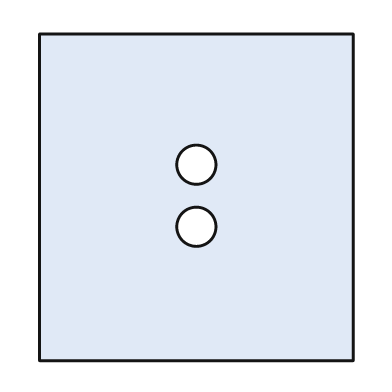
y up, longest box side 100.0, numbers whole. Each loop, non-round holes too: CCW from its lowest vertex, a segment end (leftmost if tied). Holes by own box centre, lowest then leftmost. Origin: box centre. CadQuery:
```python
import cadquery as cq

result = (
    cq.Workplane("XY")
    .moveTo(-48.0, -50.0)
    .lineTo(48.0, -50.0)
    .lineTo(48.0, 50.0)
    .lineTo(-48.0, 50.0)
    .close()
    .moveTo(0.0, -9.0)
    .circle(6.0)
    .moveTo(0.0, 10.0)
    .circle(6.0)
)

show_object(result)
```